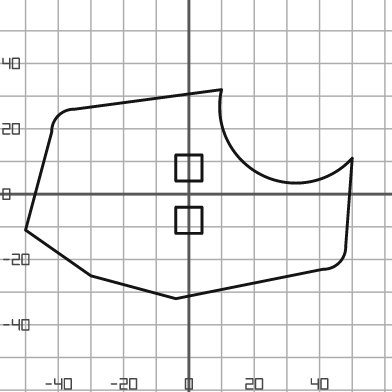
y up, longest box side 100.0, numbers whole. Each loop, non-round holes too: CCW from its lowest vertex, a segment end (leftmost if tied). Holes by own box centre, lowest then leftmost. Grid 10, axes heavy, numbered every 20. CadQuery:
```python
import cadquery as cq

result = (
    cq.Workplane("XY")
    .moveTo(-4.0, -32.0)
    .lineTo(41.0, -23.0)
    .threePointArc((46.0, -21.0), (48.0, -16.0))
    .lineTo(50.0, 11.0)
    .threePointArc((22.0, 6.0), (10.0, 32.0))
    .lineTo(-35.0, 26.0)
    .threePointArc((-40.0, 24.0), (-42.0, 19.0))
    .lineTo(-50.0, -11.0)
    .lineTo(-30.0, -25.0)
    .close()
    .moveTo(-4.0, -12.0)
    .lineTo(4.0, -12.0)
    .lineTo(4.0, -4.0)
    .lineTo(-4.0, -4.0)
    .close()
    .moveTo(-4.0, 4.0)
    .lineTo(4.0, 4.0)
    .lineTo(4.0, 12.0)
    .lineTo(-4.0, 12.0)
    .close()
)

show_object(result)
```